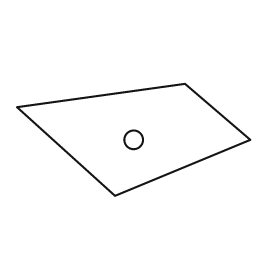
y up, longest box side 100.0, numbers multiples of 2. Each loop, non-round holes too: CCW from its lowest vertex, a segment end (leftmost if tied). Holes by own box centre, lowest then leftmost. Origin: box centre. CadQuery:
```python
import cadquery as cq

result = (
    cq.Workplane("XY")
    .moveTo(-8.0, -24.0)
    .lineTo(50.0, 0.0)
    .lineTo(22.0, 24.0)
    .lineTo(-50.0, 14.0)
    .close()
    .moveTo(0.0, 0.0)
    .circle(4.0)
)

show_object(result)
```